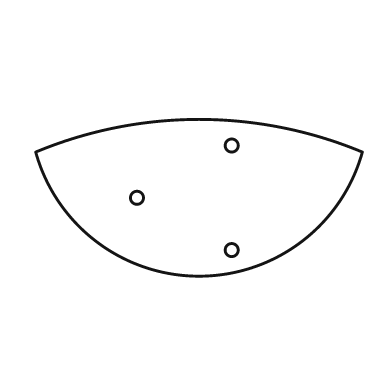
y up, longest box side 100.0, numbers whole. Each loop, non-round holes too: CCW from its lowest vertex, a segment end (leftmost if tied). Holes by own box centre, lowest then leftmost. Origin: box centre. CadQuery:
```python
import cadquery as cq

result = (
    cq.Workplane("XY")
    .moveTo(-50.0, 14.0)
    .threePointArc((0.0, -24.0), (50.0, 14.0))
    .threePointArc((0.0, 24.0), (-50.0, 14.0))
    .close()
    .moveTo(10.0, -16.0)
    .circle(2.0)
    .moveTo(-19.0, 0.0)
    .circle(2.0)
    .moveTo(10.0, 16.0)
    .circle(2.0)
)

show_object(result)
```